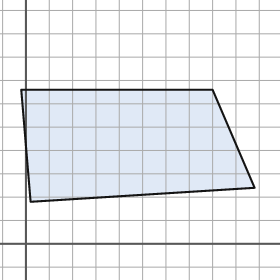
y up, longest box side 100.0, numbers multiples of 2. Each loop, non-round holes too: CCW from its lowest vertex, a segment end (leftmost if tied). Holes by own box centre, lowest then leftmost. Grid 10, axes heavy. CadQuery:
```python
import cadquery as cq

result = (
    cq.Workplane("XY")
    .moveTo(2.0, 18.0)
    .lineTo(98.0, 24.0)
    .lineTo(80.0, 66.0)
    .lineTo(-2.0, 66.0)
    .close()
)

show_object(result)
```